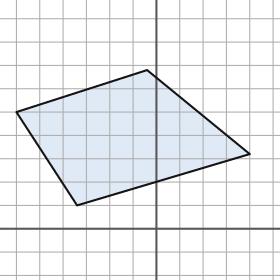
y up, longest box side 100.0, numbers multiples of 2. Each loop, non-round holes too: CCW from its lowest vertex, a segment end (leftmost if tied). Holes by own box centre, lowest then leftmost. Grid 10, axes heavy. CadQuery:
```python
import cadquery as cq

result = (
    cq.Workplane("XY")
    .moveTo(-34.0, 10.0)
    .lineTo(40.0, 32.0)
    .lineTo(-4.0, 68.0)
    .lineTo(-60.0, 50.0)
    .close()
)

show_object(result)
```